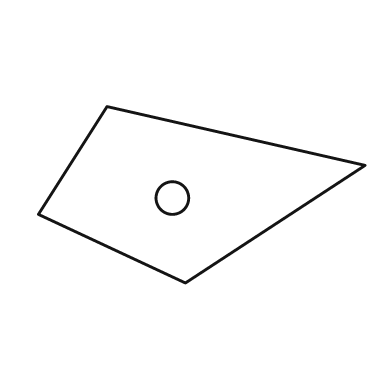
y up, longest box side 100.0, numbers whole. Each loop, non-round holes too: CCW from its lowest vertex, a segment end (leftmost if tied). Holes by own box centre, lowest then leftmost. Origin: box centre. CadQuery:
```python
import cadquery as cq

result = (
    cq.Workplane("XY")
    .moveTo(-5.0, -27.0)
    .lineTo(50.0, 9.0)
    .lineTo(-29.0, 27.0)
    .lineTo(-50.0, -6.0)
    .close()
    .moveTo(-9.0, -1.0)
    .circle(5.0)
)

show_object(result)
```